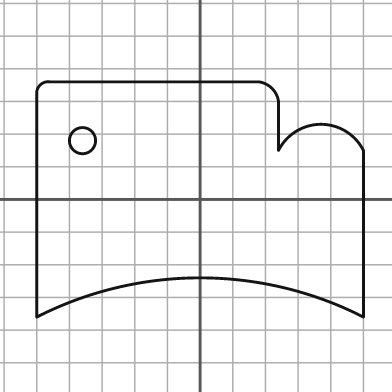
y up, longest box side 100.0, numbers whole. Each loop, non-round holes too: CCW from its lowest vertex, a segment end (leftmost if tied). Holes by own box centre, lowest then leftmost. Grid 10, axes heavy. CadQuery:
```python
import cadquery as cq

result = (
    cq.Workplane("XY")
    .moveTo(-50.0, -36.0)
    .threePointArc((0.0, -24.0), (50.0, -36.0))
    .lineTo(50.0, 15.0)
    .threePointArc((37.0, 23.0), (24.0, 15.0))
    .lineTo(24.0, 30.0)
    .threePointArc((22.0, 34.0), (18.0, 36.0))
    .lineTo(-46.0, 36.0)
    .threePointArc((-49.0, 35.0), (-50.0, 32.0))
    .close()
    .moveTo(-36.0, 18.0)
    .circle(4.0)
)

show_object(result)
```